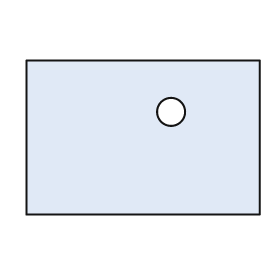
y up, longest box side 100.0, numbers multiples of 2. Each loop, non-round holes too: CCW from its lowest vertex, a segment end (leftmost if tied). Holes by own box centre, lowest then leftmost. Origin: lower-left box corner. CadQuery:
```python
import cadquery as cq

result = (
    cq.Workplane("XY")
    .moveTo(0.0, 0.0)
    .lineTo(100.0, 0.0)
    .lineTo(100.0, 66.0)
    .lineTo(0.0, 66.0)
    .close()
    .moveTo(62.0, 44.0)
    .circle(6.0)
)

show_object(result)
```